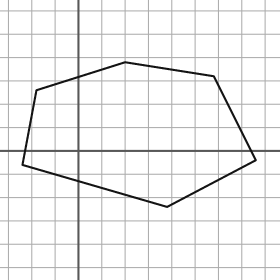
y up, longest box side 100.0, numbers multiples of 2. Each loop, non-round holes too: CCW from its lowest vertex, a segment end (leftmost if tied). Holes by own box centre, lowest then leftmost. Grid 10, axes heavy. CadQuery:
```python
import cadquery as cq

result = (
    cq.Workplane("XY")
    .moveTo(38.0, -24.0)
    .lineTo(76.0, -4.0)
    .lineTo(58.0, 32.0)
    .lineTo(20.0, 38.0)
    .lineTo(-18.0, 26.0)
    .lineTo(-24.0, -6.0)
    .close()
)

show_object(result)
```